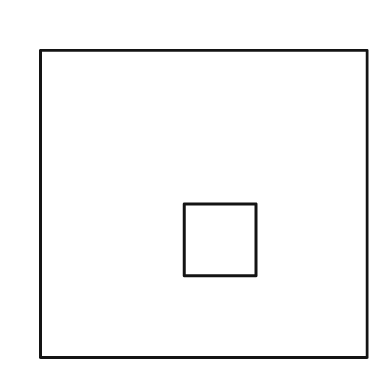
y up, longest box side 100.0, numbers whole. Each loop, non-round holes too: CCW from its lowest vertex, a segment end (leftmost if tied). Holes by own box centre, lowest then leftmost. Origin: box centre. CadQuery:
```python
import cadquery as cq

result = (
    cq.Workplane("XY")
    .moveTo(-50.0, -47.0)
    .lineTo(50.0, -47.0)
    .lineTo(50.0, 47.0)
    .lineTo(-50.0, 47.0)
    .close()
    .moveTo(-6.0, -22.0)
    .lineTo(16.0, -22.0)
    .lineTo(16.0, 0.0)
    .lineTo(-6.0, 0.0)
    .close()
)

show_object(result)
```